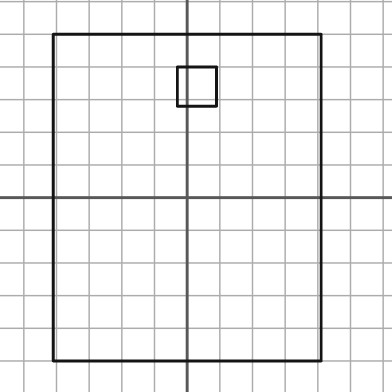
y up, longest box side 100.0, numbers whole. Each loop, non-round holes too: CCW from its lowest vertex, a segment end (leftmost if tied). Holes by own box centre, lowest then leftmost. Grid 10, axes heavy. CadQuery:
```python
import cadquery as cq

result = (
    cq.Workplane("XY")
    .moveTo(-41.0, -50.0)
    .lineTo(41.0, -50.0)
    .lineTo(41.0, 50.0)
    .lineTo(-41.0, 50.0)
    .close()
    .moveTo(-3.0, 28.0)
    .lineTo(9.0, 28.0)
    .lineTo(9.0, 40.0)
    .lineTo(-3.0, 40.0)
    .close()
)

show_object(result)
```